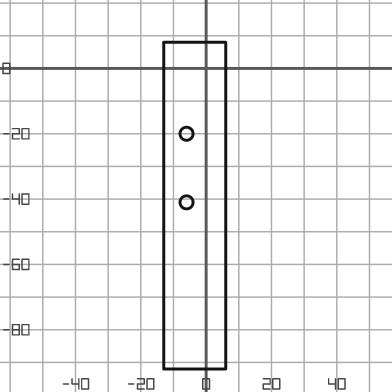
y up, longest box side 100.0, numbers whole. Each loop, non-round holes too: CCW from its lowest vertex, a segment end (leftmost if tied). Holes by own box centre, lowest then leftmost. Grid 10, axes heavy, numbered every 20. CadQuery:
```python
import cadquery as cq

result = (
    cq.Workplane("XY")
    .moveTo(-13.0, -92.0)
    .lineTo(6.0, -92.0)
    .lineTo(6.0, 8.0)
    .lineTo(-13.0, 8.0)
    .close()
    .moveTo(-6.0, -41.0)
    .circle(2.0)
    .moveTo(-6.0, -20.0)
    .circle(2.0)
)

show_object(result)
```